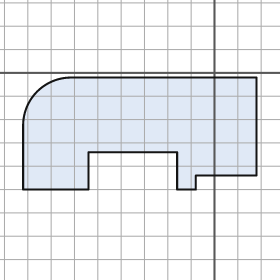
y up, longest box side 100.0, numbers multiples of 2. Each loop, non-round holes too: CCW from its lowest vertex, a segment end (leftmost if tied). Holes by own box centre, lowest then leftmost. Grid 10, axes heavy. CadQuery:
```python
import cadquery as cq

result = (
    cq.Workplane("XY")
    .moveTo(-82.0, -50.0)
    .lineTo(-54.0, -50.0)
    .lineTo(-54.0, -34.0)
    .lineTo(-16.0, -34.0)
    .lineTo(-16.0, -50.0)
    .lineTo(-8.0, -50.0)
    .lineTo(-8.0, -44.0)
    .lineTo(18.0, -44.0)
    .lineTo(18.0, -2.0)
    .lineTo(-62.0, -2.0)
    .threePointArc((-76.0, -8.0), (-82.0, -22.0))
    .close()
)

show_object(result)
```